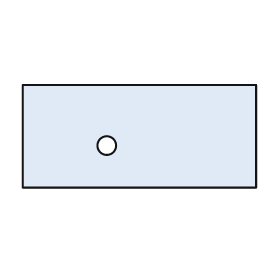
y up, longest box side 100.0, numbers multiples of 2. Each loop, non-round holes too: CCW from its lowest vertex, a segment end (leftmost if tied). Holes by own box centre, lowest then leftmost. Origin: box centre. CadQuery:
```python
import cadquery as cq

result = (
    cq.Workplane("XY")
    .moveTo(-50.0, -22.0)
    .lineTo(50.0, -22.0)
    .lineTo(50.0, 22.0)
    .lineTo(-50.0, 22.0)
    .close()
    .moveTo(-14.0, -4.0)
    .circle(4.0)
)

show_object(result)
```